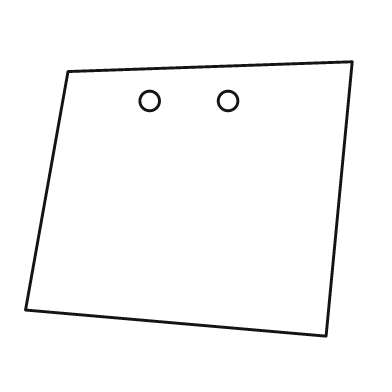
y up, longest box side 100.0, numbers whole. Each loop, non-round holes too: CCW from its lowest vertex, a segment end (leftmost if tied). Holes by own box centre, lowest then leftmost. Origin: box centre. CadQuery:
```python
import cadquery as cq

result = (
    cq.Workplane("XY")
    .moveTo(42.0, -42.0)
    .lineTo(50.0, 42.0)
    .lineTo(-37.0, 39.0)
    .lineTo(-50.0, -34.0)
    .close()
    .moveTo(-12.0, 30.0)
    .circle(3.0)
    .moveTo(12.0, 30.0)
    .circle(3.0)
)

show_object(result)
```